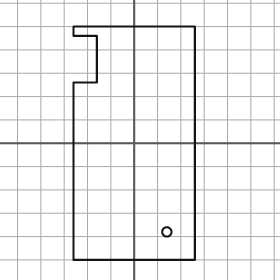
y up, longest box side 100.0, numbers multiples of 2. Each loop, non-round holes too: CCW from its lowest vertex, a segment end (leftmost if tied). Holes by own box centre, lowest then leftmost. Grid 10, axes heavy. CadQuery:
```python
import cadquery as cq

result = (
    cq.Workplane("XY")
    .moveTo(-26.0, -50.0)
    .lineTo(26.0, -50.0)
    .lineTo(26.0, 50.0)
    .lineTo(-26.0, 50.0)
    .lineTo(-26.0, 46.0)
    .lineTo(-16.0, 46.0)
    .lineTo(-16.0, 26.0)
    .lineTo(-26.0, 26.0)
    .close()
    .moveTo(14.0, -38.0)
    .circle(2.0)
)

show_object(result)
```